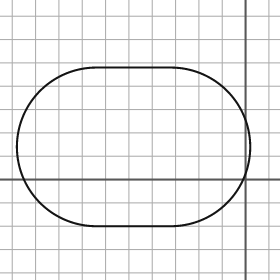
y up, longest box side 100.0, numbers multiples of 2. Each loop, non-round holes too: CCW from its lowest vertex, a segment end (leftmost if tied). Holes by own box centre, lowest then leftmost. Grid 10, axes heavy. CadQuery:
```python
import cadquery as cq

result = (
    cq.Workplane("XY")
    .moveTo(-64.0, -20.0)
    .lineTo(-32.0, -20.0)
    .threePointArc((2.0, 14.0), (-32.0, 48.0))
    .lineTo(-64.0, 48.0)
    .threePointArc((-98.0, 14.0), (-64.0, -20.0))
    .close()
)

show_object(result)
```